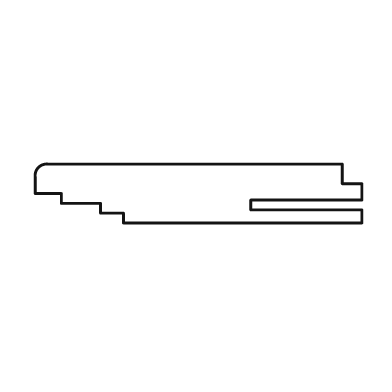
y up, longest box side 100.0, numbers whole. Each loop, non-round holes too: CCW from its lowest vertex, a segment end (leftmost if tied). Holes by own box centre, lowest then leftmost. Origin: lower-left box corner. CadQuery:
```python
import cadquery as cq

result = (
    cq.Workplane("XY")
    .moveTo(27.0, 0.0)
    .lineTo(100.0, 0.0)
    .lineTo(100.0, 4.0)
    .lineTo(66.0, 4.0)
    .lineTo(66.0, 7.0)
    .lineTo(100.0, 7.0)
    .lineTo(100.0, 12.0)
    .lineTo(94.0, 12.0)
    .lineTo(94.0, 18.0)
    .lineTo(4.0, 18.0)
    .threePointArc((1.0, 17.0), (0.0, 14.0))
    .lineTo(0.0, 9.0)
    .lineTo(8.0, 9.0)
    .lineTo(8.0, 6.0)
    .lineTo(20.0, 6.0)
    .lineTo(20.0, 3.0)
    .lineTo(27.0, 3.0)
    .close()
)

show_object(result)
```